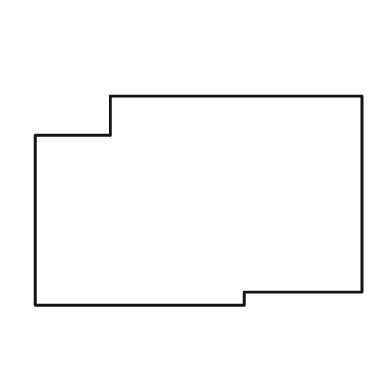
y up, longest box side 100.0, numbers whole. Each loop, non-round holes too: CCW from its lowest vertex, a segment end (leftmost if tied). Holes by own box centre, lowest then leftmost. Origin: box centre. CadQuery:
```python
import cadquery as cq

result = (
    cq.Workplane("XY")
    .moveTo(-50.0, -32.0)
    .lineTo(14.0, -32.0)
    .lineTo(14.0, -28.0)
    .lineTo(50.0, -28.0)
    .lineTo(50.0, 32.0)
    .lineTo(-27.0, 32.0)
    .lineTo(-27.0, 20.0)
    .lineTo(-50.0, 20.0)
    .close()
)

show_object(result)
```